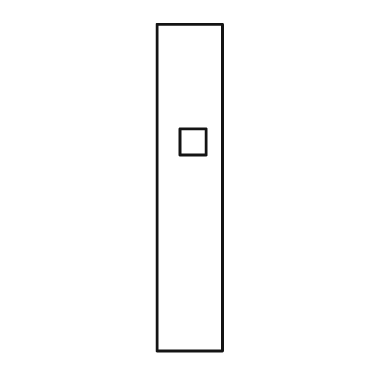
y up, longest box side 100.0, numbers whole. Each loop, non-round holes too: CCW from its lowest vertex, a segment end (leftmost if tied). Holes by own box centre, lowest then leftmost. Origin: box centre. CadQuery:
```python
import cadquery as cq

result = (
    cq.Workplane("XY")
    .moveTo(-10.0, -50.0)
    .lineTo(10.0, -50.0)
    .lineTo(10.0, 50.0)
    .lineTo(-10.0, 50.0)
    .close()
    .moveTo(-3.0, 10.0)
    .lineTo(5.0, 10.0)
    .lineTo(5.0, 18.0)
    .lineTo(-3.0, 18.0)
    .close()
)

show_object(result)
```